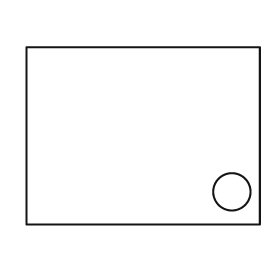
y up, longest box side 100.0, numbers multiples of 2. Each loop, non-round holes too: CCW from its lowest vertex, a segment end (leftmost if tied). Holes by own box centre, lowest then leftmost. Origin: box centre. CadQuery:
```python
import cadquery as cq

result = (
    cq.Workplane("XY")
    .moveTo(-50.0, -38.0)
    .lineTo(50.0, -38.0)
    .lineTo(50.0, 38.0)
    .lineTo(-50.0, 38.0)
    .close()
    .moveTo(38.0, -24.0)
    .circle(8.0)
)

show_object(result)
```